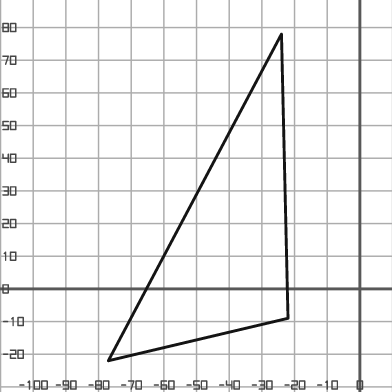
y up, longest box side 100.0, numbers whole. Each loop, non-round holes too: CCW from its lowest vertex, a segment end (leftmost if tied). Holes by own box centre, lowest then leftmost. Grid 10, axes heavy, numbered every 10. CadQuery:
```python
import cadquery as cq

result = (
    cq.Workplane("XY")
    .moveTo(-77.0, -22.0)
    .lineTo(-22.0, -9.0)
    .lineTo(-24.0, 78.0)
    .close()
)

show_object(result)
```